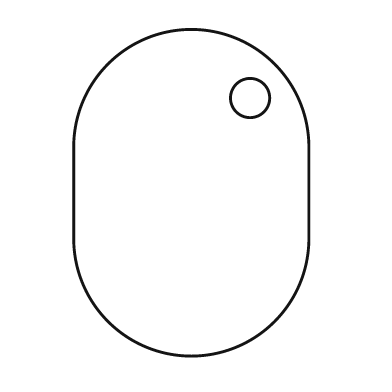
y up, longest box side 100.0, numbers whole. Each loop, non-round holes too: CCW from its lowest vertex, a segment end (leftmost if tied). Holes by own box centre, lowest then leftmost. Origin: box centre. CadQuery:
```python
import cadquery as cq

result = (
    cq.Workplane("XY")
    .moveTo(-36.0, -14.0)
    .threePointArc((0.0, -50.0), (36.0, -14.0))
    .lineTo(36.0, 14.0)
    .threePointArc((0.0, 50.0), (-36.0, 14.0))
    .close()
    .moveTo(18.0, 29.0)
    .circle(6.0)
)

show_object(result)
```